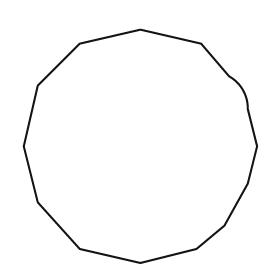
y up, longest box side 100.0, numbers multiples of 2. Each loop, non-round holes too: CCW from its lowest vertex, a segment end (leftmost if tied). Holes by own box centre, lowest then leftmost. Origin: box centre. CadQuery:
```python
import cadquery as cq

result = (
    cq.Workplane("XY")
    .moveTo(0.0, -50.0)
    .lineTo(24.0, -44.0)
    .lineTo(36.0, -34.0)
    .lineTo(46.0, -16.0)
    .lineTo(50.0, 0.0)
    .lineTo(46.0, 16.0)
    .threePointArc((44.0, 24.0), (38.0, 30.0))
    .lineTo(26.0, 44.0)
    .lineTo(0.0, 50.0)
    .lineTo(-26.0, 44.0)
    .lineTo(-44.0, 26.0)
    .lineTo(-50.0, 0.0)
    .lineTo(-44.0, -24.0)
    .lineTo(-26.0, -44.0)
    .close()
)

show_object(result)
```